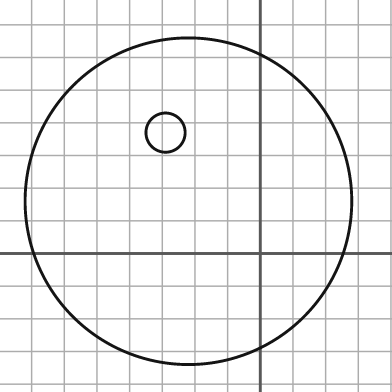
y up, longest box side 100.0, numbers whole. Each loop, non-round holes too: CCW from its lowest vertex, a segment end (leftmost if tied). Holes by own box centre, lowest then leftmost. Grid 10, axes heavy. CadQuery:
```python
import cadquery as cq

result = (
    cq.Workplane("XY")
    .moveTo(-22.0, 16.0)
    .circle(50.0)
    .moveTo(-29.0, 37.0)
    .circle(6.0)
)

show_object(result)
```